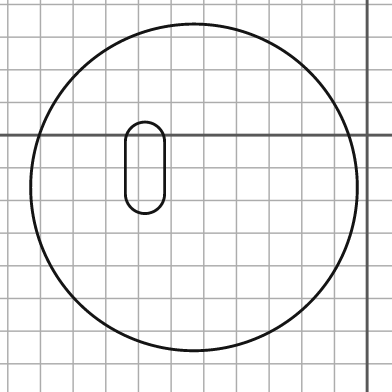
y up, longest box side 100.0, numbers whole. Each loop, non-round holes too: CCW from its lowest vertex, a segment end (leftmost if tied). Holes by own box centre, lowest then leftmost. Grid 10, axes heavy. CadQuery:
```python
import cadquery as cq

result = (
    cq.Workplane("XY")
    .moveTo(-53.0, -16.0)
    .circle(50.0)
    .moveTo(-74.0, -18.0)
    .threePointArc((-68.0, -24.0), (-62.0, -18.0))
    .lineTo(-62.0, -2.0)
    .threePointArc((-68.0, 4.0), (-74.0, -2.0))
    .close()
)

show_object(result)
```